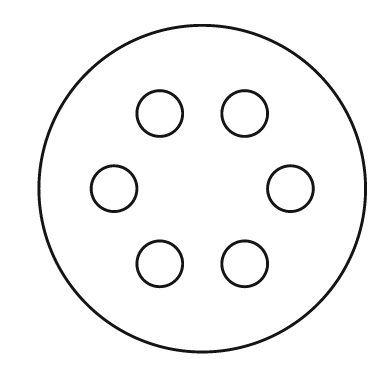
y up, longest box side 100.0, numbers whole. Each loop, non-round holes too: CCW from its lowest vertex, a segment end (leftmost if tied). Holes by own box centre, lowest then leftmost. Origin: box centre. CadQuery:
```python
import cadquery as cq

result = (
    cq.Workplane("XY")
    .moveTo(0.0, 0.0)
    .circle(50.0)
    .moveTo(-13.0, -23.0)
    .circle(7.0)
    .moveTo(13.0, -23.0)
    .circle(7.0)
    .moveTo(-27.0, 0.0)
    .circle(7.0)
    .moveTo(27.0, 0.0)
    .circle(7.0)
    .moveTo(-13.0, 23.0)
    .circle(7.0)
    .moveTo(13.0, 23.0)
    .circle(7.0)
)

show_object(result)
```